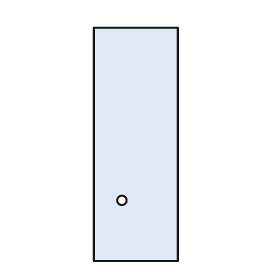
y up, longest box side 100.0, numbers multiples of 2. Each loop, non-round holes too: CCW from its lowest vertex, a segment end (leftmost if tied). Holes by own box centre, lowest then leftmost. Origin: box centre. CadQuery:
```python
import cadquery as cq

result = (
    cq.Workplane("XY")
    .moveTo(-18.0, -50.0)
    .lineTo(18.0, -50.0)
    .lineTo(18.0, 50.0)
    .lineTo(-18.0, 50.0)
    .close()
    .moveTo(-6.0, -24.0)
    .circle(2.0)
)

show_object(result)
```